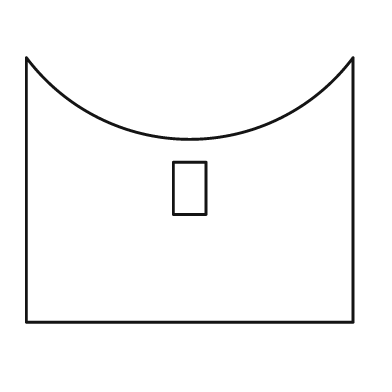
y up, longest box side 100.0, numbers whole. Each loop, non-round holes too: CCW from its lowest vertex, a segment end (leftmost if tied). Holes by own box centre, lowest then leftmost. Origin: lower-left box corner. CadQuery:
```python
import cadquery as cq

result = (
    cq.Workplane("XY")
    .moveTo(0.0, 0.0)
    .lineTo(100.0, 0.0)
    .lineTo(100.0, 81.0)
    .threePointArc((50.0, 56.0), (0.0, 81.0))
    .close()
    .moveTo(45.0, 33.0)
    .lineTo(55.0, 33.0)
    .lineTo(55.0, 49.0)
    .lineTo(45.0, 49.0)
    .close()
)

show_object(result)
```